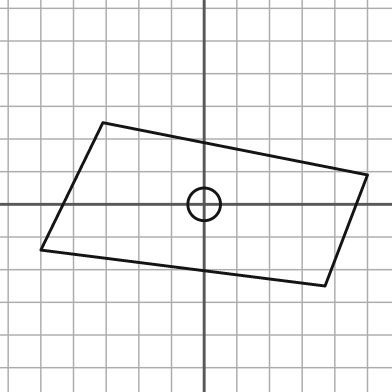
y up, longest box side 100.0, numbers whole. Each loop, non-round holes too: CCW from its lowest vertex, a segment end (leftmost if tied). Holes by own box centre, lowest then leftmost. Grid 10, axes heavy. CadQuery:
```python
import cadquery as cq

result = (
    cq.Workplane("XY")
    .moveTo(37.0, -25.0)
    .lineTo(50.0, 9.0)
    .lineTo(-31.0, 25.0)
    .lineTo(-50.0, -14.0)
    .close()
    .moveTo(0.0, 0.0)
    .circle(5.0)
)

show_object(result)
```